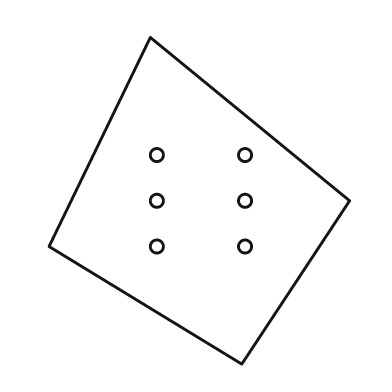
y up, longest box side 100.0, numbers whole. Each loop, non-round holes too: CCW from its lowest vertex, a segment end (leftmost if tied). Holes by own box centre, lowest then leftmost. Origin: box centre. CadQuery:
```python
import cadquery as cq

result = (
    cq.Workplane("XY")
    .moveTo(13.0, -50.0)
    .lineTo(46.0, 0.0)
    .lineTo(-15.0, 50.0)
    .lineTo(-46.0, -14.0)
    .close()
    .moveTo(-13.0, -14.0)
    .circle(2.0)
    .moveTo(14.0, -14.0)
    .circle(2.0)
    .moveTo(-13.0, 0.0)
    .circle(2.0)
    .moveTo(14.0, 0.0)
    .circle(2.0)
    .moveTo(-13.0, 14.0)
    .circle(2.0)
    .moveTo(14.0, 14.0)
    .circle(2.0)
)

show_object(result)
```